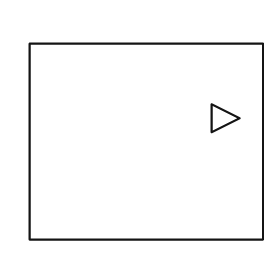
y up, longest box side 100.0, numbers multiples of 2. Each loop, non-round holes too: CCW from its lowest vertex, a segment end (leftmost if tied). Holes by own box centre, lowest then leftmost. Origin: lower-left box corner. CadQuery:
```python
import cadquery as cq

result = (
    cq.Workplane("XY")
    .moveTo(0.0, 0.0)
    .lineTo(100.0, 0.0)
    .lineTo(100.0, 84.0)
    .lineTo(0.0, 84.0)
    .close()
    .moveTo(78.0, 46.0)
    .lineTo(90.0, 52.0)
    .lineTo(78.0, 58.0)
    .close()
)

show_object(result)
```